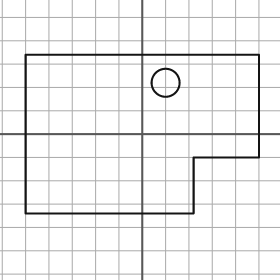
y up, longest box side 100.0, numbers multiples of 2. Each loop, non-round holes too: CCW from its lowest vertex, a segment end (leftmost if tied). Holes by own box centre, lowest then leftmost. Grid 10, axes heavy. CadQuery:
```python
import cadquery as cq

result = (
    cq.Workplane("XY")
    .moveTo(-50.0, -34.0)
    .lineTo(22.0, -34.0)
    .lineTo(22.0, -10.0)
    .lineTo(50.0, -10.0)
    .lineTo(50.0, 34.0)
    .lineTo(-50.0, 34.0)
    .close()
    .moveTo(10.0, 22.0)
    .circle(6.0)
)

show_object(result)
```